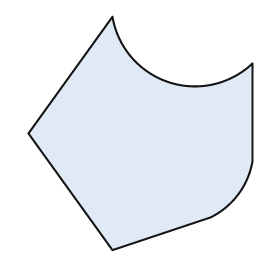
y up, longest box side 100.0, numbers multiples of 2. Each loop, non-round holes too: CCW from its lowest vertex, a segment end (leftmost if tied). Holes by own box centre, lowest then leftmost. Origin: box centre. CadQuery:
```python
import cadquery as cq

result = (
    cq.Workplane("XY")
    .moveTo(-12.0, -50.0)
    .lineTo(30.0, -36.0)
    .threePointArc((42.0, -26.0), (48.0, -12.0))
    .lineTo(48.0, 30.0)
    .threePointArc((12.0, 22.0), (-12.0, 50.0))
    .lineTo(-48.0, 0.0)
    .close()
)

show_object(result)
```